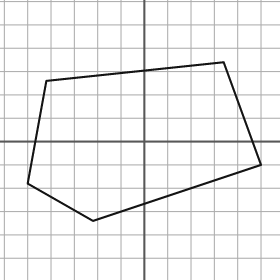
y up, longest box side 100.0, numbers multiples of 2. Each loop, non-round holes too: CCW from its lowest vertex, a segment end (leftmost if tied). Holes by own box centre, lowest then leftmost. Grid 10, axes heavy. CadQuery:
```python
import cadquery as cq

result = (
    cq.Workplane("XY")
    .moveTo(-22.0, -34.0)
    .lineTo(50.0, -10.0)
    .lineTo(34.0, 34.0)
    .lineTo(-42.0, 26.0)
    .lineTo(-50.0, -18.0)
    .close()
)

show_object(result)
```